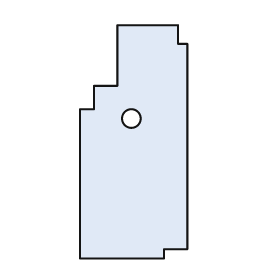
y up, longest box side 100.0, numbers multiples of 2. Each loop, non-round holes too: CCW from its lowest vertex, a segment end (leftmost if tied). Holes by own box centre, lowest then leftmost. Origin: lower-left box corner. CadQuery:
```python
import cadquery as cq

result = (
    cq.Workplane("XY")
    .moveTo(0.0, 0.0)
    .lineTo(36.0, 0.0)
    .lineTo(36.0, 4.0)
    .lineTo(46.0, 4.0)
    .lineTo(46.0, 92.0)
    .lineTo(42.0, 92.0)
    .lineTo(42.0, 100.0)
    .lineTo(16.0, 100.0)
    .lineTo(16.0, 74.0)
    .lineTo(6.0, 74.0)
    .lineTo(6.0, 64.0)
    .lineTo(0.0, 64.0)
    .close()
    .moveTo(22.0, 60.0)
    .circle(4.0)
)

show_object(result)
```